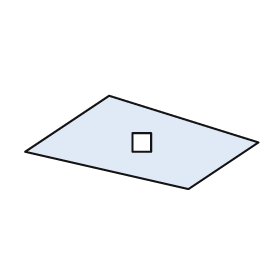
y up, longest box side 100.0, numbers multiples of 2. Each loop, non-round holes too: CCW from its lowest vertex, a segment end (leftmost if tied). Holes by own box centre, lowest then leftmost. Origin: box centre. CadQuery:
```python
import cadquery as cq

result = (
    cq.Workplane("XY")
    .moveTo(20.0, -20.0)
    .lineTo(50.0, 0.0)
    .lineTo(-14.0, 20.0)
    .lineTo(-50.0, -4.0)
    .close()
    .moveTo(-4.0, -4.0)
    .lineTo(4.0, -4.0)
    .lineTo(4.0, 4.0)
    .lineTo(-4.0, 4.0)
    .close()
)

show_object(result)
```